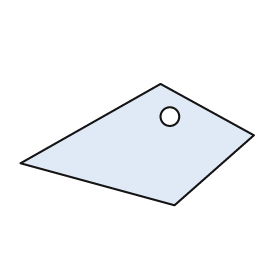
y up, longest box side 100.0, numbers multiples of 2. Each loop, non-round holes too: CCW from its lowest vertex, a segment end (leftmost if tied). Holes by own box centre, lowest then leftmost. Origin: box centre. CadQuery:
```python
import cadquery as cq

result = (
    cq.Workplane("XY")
    .moveTo(16.0, -26.0)
    .lineTo(50.0, 4.0)
    .lineTo(10.0, 26.0)
    .lineTo(-50.0, -8.0)
    .close()
    .moveTo(14.0, 12.0)
    .circle(4.0)
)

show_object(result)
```